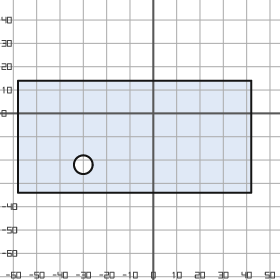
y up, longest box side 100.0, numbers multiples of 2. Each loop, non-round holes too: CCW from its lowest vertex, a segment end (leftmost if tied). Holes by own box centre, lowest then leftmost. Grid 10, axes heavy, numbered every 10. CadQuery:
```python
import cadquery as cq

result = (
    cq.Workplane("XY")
    .moveTo(-58.0, -34.0)
    .lineTo(42.0, -34.0)
    .lineTo(42.0, 14.0)
    .lineTo(-58.0, 14.0)
    .close()
    .moveTo(-30.0, -22.0)
    .circle(4.0)
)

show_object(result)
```